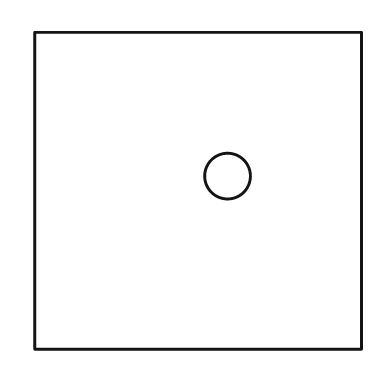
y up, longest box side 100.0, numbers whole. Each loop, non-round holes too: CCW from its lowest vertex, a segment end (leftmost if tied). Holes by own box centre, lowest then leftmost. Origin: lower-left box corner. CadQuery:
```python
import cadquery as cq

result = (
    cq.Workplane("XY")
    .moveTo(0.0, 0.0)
    .lineTo(100.0, 0.0)
    .lineTo(100.0, 97.0)
    .lineTo(0.0, 97.0)
    .close()
    .moveTo(59.0, 53.0)
    .circle(7.0)
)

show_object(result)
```